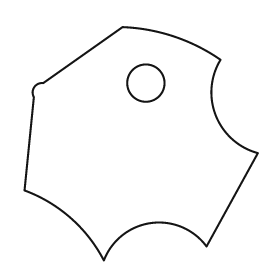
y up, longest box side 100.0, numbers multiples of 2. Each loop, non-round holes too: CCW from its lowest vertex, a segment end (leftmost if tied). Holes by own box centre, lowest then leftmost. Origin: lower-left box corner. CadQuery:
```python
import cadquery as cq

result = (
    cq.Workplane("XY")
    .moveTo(34.0, 0.0)
    .threePointArc((54.0, 16.0), (78.0, 6.0))
    .lineTo(100.0, 46.0)
    .threePointArc((82.0, 62.0), (84.0, 86.0))
    .threePointArc((64.0, 96.0), (42.0, 100.0))
    .lineTo(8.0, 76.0)
    .threePointArc((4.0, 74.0), (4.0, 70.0))
    .lineTo(0.0, 30.0)
    .threePointArc((20.0, 18.0), (34.0, 0.0))
    .close()
    .moveTo(52.0, 76.0)
    .circle(8.0)
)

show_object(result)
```